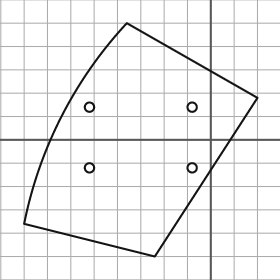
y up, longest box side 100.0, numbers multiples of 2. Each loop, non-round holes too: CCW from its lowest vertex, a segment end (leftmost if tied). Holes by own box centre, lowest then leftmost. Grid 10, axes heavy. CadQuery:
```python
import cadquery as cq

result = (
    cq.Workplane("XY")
    .moveTo(-24.0, -50.0)
    .lineTo(20.0, 18.0)
    .lineTo(-36.0, 50.0)
    .threePointArc((-64.0, 10.0), (-80.0, -36.0))
    .close()
    .moveTo(-52.0, -12.0)
    .circle(2.0)
    .moveTo(-8.0, -12.0)
    .circle(2.0)
    .moveTo(-52.0, 14.0)
    .circle(2.0)
    .moveTo(-8.0, 14.0)
    .circle(2.0)
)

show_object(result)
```